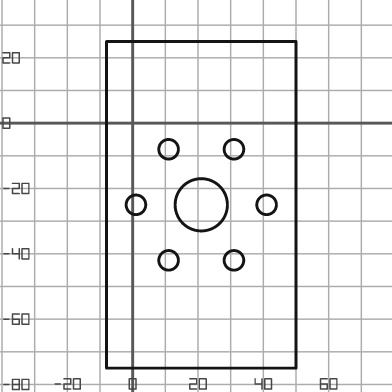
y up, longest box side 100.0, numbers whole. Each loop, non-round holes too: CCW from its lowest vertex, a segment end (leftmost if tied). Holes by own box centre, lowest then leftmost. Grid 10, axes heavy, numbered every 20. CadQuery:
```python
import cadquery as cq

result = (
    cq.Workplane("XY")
    .moveTo(-8.0, -75.0)
    .lineTo(50.0, -75.0)
    .lineTo(50.0, 25.0)
    .lineTo(-8.0, 25.0)
    .close()
    .moveTo(11.0, -42.0)
    .circle(3.0)
    .moveTo(31.0, -42.0)
    .circle(3.0)
    .moveTo(1.0, -25.0)
    .circle(3.0)
    .moveTo(21.0, -25.0)
    .circle(8.0)
    .moveTo(41.0, -25.0)
    .circle(3.0)
    .moveTo(11.0, -8.0)
    .circle(3.0)
    .moveTo(31.0, -8.0)
    .circle(3.0)
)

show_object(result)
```